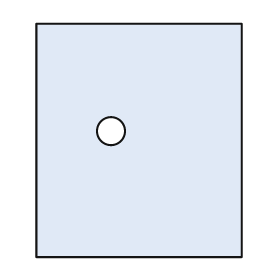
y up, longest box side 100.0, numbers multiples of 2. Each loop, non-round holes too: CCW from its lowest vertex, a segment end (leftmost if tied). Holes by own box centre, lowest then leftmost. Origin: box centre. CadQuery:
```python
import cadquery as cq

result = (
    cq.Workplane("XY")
    .moveTo(-44.0, -50.0)
    .lineTo(44.0, -50.0)
    .lineTo(44.0, 50.0)
    .lineTo(-44.0, 50.0)
    .close()
    .moveTo(-12.0, 4.0)
    .circle(6.0)
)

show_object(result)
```